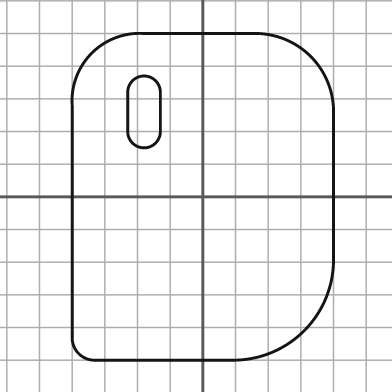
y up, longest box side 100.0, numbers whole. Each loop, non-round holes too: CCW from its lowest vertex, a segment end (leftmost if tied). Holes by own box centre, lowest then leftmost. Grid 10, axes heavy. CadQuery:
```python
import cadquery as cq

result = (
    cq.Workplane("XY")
    .moveTo(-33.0, -50.0)
    .lineTo(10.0, -50.0)
    .threePointArc((31.0, -41.0), (40.0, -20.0))
    .lineTo(40.0, 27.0)
    .threePointArc((33.0, 43.0), (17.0, 50.0))
    .lineTo(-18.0, 50.0)
    .threePointArc((-34.0, 44.0), (-40.0, 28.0))
    .lineTo(-40.0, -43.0)
    .threePointArc((-38.0, -48.0), (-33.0, -50.0))
    .close()
    .moveTo(-23.0, 20.0)
    .threePointArc((-18.0, 15.0), (-13.0, 20.0))
    .lineTo(-13.0, 32.0)
    .threePointArc((-18.0, 37.0), (-23.0, 32.0))
    .close()
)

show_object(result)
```